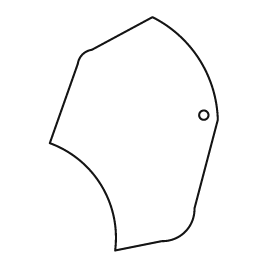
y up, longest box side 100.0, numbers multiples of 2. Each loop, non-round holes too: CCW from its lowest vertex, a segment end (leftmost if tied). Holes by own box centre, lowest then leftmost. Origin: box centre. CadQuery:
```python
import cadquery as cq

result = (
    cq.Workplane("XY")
    .moveTo(-8.0, -50.0)
    .lineTo(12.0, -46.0)
    .threePointArc((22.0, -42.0), (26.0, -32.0))
    .lineTo(36.0, 6.0)
    .threePointArc((28.0, 32.0), (8.0, 50.0))
    .lineTo(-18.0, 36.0)
    .threePointArc((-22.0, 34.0), (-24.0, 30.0))
    .lineTo(-36.0, -4.0)
    .threePointArc((-14.0, -22.0), (-8.0, -50.0))
    .close()
    .moveTo(30.0, 8.0)
    .circle(2.0)
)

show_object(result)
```